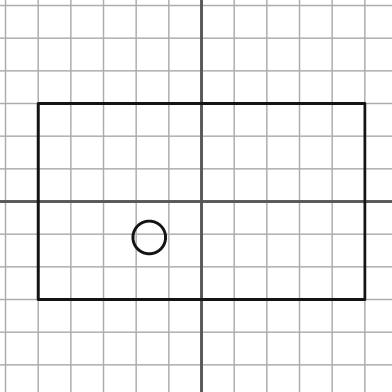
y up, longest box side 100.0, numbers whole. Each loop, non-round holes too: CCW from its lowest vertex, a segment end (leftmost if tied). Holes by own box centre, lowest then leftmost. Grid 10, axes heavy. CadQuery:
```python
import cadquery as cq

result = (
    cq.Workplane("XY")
    .moveTo(-50.0, -30.0)
    .lineTo(50.0, -30.0)
    .lineTo(50.0, 30.0)
    .lineTo(-50.0, 30.0)
    .close()
    .moveTo(-16.0, -11.0)
    .circle(5.0)
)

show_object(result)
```